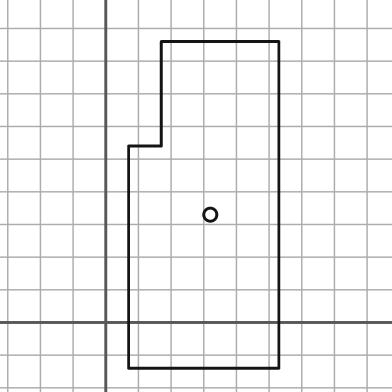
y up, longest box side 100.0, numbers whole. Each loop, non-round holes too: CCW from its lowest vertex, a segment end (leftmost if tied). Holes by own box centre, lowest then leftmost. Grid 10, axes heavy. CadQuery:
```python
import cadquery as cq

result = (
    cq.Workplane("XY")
    .moveTo(7.0, -14.0)
    .lineTo(53.0, -14.0)
    .lineTo(53.0, 86.0)
    .lineTo(17.0, 86.0)
    .lineTo(17.0, 54.0)
    .lineTo(7.0, 54.0)
    .close()
    .moveTo(32.0, 33.0)
    .circle(2.0)
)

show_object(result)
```